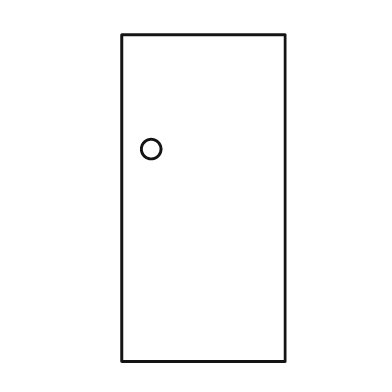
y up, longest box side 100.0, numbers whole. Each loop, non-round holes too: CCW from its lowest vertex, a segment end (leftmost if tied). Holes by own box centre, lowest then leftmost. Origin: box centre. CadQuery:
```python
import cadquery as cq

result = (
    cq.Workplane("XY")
    .moveTo(-25.0, -50.0)
    .lineTo(25.0, -50.0)
    .lineTo(25.0, 50.0)
    .lineTo(-25.0, 50.0)
    .close()
    .moveTo(-16.0, 15.0)
    .circle(3.0)
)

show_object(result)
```